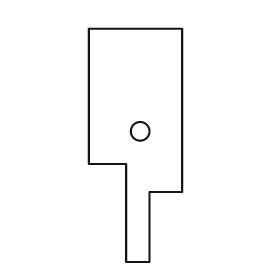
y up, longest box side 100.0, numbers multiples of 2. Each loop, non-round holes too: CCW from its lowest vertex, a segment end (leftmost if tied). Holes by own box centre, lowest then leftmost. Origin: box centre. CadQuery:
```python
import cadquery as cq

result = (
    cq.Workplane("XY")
    .moveTo(-4.0, -50.0)
    .lineTo(6.0, -50.0)
    .lineTo(6.0, -20.0)
    .lineTo(20.0, -20.0)
    .lineTo(20.0, 50.0)
    .lineTo(-20.0, 50.0)
    .lineTo(-20.0, -8.0)
    .lineTo(-4.0, -8.0)
    .close()
    .moveTo(2.0, 6.0)
    .circle(4.0)
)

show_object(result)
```